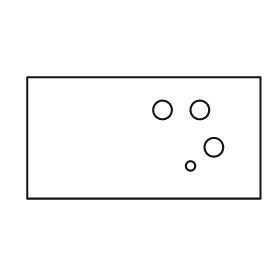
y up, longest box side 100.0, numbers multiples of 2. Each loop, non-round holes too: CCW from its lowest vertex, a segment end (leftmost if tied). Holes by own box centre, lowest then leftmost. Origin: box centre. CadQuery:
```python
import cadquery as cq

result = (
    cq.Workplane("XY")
    .moveTo(-50.0, -26.0)
    .lineTo(50.0, -26.0)
    .lineTo(50.0, 26.0)
    .lineTo(-50.0, 26.0)
    .close()
    .moveTo(20.0, -12.0)
    .circle(2.0)
    .moveTo(30.0, -4.0)
    .circle(4.0)
    .moveTo(8.0, 12.0)
    .circle(4.0)
    .moveTo(24.0, 12.0)
    .circle(4.0)
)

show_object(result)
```